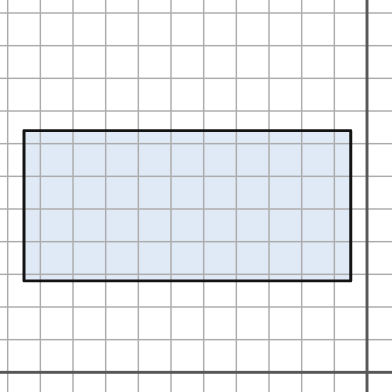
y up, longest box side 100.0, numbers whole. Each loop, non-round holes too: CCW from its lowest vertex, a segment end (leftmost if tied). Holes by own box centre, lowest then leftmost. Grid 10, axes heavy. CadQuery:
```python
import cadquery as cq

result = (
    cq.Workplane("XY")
    .moveTo(-105.0, 28.0)
    .lineTo(-5.0, 28.0)
    .lineTo(-5.0, 74.0)
    .lineTo(-105.0, 74.0)
    .close()
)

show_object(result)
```